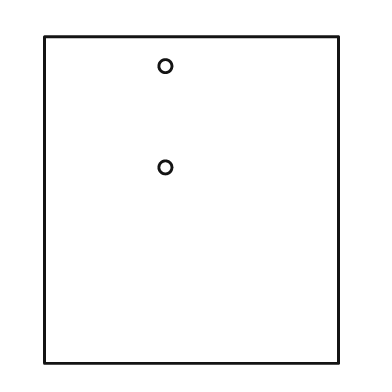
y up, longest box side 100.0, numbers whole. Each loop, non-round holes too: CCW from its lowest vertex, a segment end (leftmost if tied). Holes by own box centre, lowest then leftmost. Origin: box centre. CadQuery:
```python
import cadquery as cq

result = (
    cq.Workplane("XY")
    .moveTo(-45.0, -50.0)
    .lineTo(45.0, -50.0)
    .lineTo(45.0, 50.0)
    .lineTo(-45.0, 50.0)
    .close()
    .moveTo(-8.0, 10.0)
    .circle(2.0)
    .moveTo(-8.0, 41.0)
    .circle(2.0)
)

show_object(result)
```